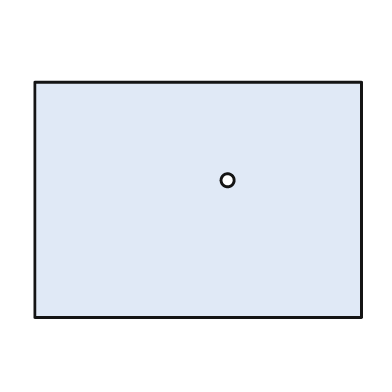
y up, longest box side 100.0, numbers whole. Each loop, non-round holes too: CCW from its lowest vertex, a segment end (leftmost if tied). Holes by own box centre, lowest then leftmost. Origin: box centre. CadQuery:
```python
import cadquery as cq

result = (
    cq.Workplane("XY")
    .moveTo(-50.0, -36.0)
    .lineTo(50.0, -36.0)
    .lineTo(50.0, 36.0)
    .lineTo(-50.0, 36.0)
    .close()
    .moveTo(9.0, 6.0)
    .circle(2.0)
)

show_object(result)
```